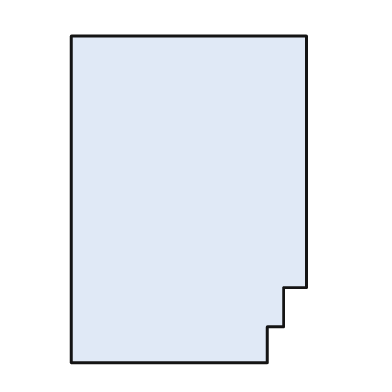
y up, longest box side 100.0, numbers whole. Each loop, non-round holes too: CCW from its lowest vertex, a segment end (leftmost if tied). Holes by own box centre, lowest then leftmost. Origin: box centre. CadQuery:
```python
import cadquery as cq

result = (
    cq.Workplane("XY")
    .moveTo(-36.0, -50.0)
    .lineTo(24.0, -50.0)
    .lineTo(24.0, -39.0)
    .lineTo(29.0, -39.0)
    .lineTo(29.0, -27.0)
    .lineTo(36.0, -27.0)
    .lineTo(36.0, 50.0)
    .lineTo(-36.0, 50.0)
    .close()
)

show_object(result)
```